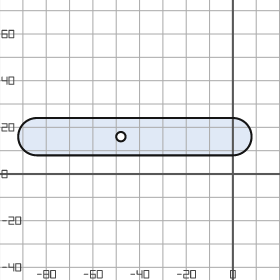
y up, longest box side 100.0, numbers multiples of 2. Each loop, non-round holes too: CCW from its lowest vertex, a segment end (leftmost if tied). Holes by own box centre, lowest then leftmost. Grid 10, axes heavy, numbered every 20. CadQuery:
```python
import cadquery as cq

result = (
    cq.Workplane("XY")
    .moveTo(-84.0, 8.0)
    .lineTo(0.0, 8.0)
    .threePointArc((8.0, 16.0), (0.0, 24.0))
    .lineTo(-84.0, 24.0)
    .threePointArc((-92.0, 16.0), (-84.0, 8.0))
    .close()
    .moveTo(-48.0, 16.0)
    .circle(2.0)
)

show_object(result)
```